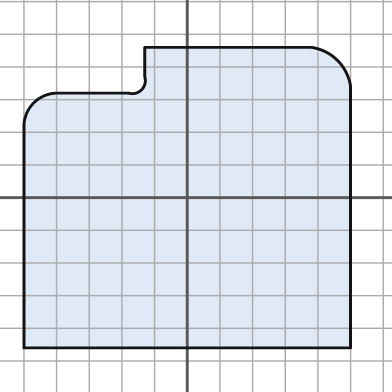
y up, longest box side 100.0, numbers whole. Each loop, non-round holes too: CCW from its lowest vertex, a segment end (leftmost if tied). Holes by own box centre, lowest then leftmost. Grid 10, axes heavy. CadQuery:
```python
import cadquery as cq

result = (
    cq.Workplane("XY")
    .moveTo(-50.0, -46.0)
    .lineTo(50.0, -46.0)
    .lineTo(50.0, 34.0)
    .threePointArc((46.0, 42.0), (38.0, 46.0))
    .lineTo(-13.0, 46.0)
    .lineTo(-13.0, 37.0)
    .threePointArc((-14.0, 33.0), (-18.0, 32.0))
    .lineTo(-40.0, 32.0)
    .threePointArc((-47.0, 29.0), (-50.0, 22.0))
    .close()
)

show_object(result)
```